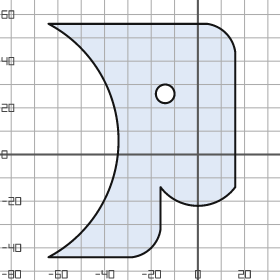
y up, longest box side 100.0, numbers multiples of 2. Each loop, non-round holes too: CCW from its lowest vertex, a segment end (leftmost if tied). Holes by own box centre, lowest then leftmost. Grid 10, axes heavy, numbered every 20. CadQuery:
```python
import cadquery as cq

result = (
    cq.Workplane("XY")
    .moveTo(-64.0, -44.0)
    .lineTo(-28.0, -44.0)
    .threePointArc((-20.0, -40.0), (-16.0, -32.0))
    .lineTo(-16.0, -14.0)
    .threePointArc((0.0, -22.0), (16.0, -14.0))
    .lineTo(16.0, 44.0)
    .threePointArc((12.0, 52.0), (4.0, 56.0))
    .lineTo(-64.0, 56.0)
    .threePointArc((-34.0, 6.0), (-64.0, -44.0))
    .close()
    .moveTo(-14.0, 26.0)
    .circle(4.0)
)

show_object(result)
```